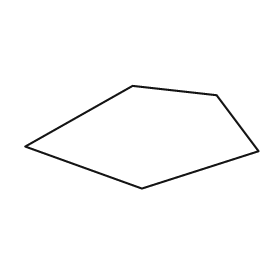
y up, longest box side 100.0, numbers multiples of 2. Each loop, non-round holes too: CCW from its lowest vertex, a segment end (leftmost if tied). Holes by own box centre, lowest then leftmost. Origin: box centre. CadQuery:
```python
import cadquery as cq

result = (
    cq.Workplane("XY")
    .moveTo(0.0, -22.0)
    .lineTo(50.0, -6.0)
    .lineTo(32.0, 18.0)
    .lineTo(-4.0, 22.0)
    .lineTo(-50.0, -4.0)
    .close()
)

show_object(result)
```